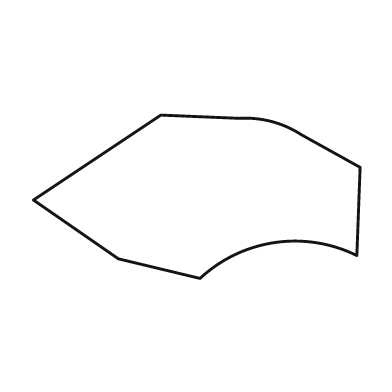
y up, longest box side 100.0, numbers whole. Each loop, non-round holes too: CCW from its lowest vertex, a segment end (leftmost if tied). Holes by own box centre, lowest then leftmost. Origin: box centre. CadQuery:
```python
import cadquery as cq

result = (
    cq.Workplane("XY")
    .moveTo(1.0, -25.0)
    .threePointArc((24.0, -14.0), (49.0, -18.0))
    .lineTo(50.0, 9.0)
    .lineTo(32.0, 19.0)
    .threePointArc((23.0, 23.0), (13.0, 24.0))
    .lineTo(-11.0, 25.0)
    .lineTo(-50.0, -1.0)
    .lineTo(-24.0, -19.0)
    .close()
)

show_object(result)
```